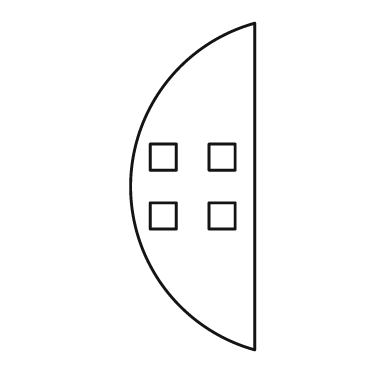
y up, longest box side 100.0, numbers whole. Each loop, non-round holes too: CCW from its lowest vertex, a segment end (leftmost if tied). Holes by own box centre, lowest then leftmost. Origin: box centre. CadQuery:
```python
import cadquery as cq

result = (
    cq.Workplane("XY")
    .moveTo(19.0, -50.0)
    .lineTo(19.0, 50.0)
    .threePointArc((-19.0, 0.0), (19.0, -50.0))
    .close()
    .moveTo(-13.0, -13.0)
    .lineTo(-5.0, -13.0)
    .lineTo(-5.0, -5.0)
    .lineTo(-13.0, -5.0)
    .close()
    .moveTo(5.0, -13.0)
    .lineTo(13.0, -13.0)
    .lineTo(13.0, -5.0)
    .lineTo(5.0, -5.0)
    .close()
    .moveTo(-13.0, 5.0)
    .lineTo(-5.0, 5.0)
    .lineTo(-5.0, 13.0)
    .lineTo(-13.0, 13.0)
    .close()
    .moveTo(5.0, 5.0)
    .lineTo(13.0, 5.0)
    .lineTo(13.0, 13.0)
    .lineTo(5.0, 13.0)
    .close()
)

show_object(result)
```